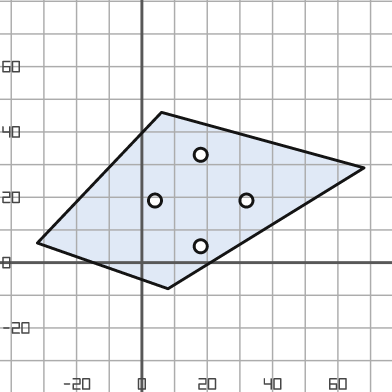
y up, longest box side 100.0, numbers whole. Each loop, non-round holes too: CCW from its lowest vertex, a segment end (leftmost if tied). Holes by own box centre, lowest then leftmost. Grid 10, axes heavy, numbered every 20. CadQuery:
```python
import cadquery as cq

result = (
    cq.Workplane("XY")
    .moveTo(8.0, -8.0)
    .lineTo(68.0, 29.0)
    .lineTo(6.0, 46.0)
    .lineTo(-32.0, 6.0)
    .close()
    .moveTo(18.0, 5.0)
    .circle(2.0)
    .moveTo(4.0, 19.0)
    .circle(2.0)
    .moveTo(32.0, 19.0)
    .circle(2.0)
    .moveTo(18.0, 33.0)
    .circle(2.0)
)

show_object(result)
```